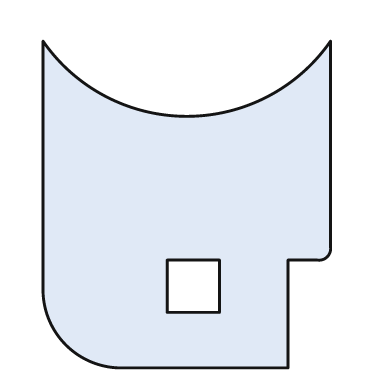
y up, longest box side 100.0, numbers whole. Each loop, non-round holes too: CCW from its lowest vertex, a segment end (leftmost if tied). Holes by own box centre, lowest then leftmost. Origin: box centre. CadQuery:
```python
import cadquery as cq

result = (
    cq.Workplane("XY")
    .moveTo(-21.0, -50.0)
    .lineTo(31.0, -50.0)
    .lineTo(31.0, -17.0)
    .lineTo(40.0, -17.0)
    .threePointArc((43.0, -16.0), (44.0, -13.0))
    .lineTo(44.0, 50.0)
    .threePointArc((0.0, 27.0), (-44.0, 50.0))
    .lineTo(-44.0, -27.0)
    .threePointArc((-37.0, -43.0), (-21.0, -50.0))
    .close()
    .moveTo(-6.0, -33.0)
    .lineTo(10.0, -33.0)
    .lineTo(10.0, -17.0)
    .lineTo(-6.0, -17.0)
    .close()
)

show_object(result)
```